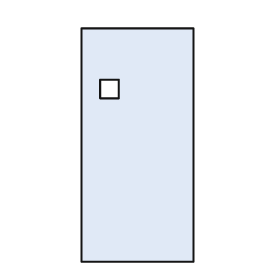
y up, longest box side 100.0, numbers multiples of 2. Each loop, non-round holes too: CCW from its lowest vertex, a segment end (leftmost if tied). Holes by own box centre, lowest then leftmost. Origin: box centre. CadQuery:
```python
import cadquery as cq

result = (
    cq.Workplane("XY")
    .moveTo(-24.0, -50.0)
    .lineTo(24.0, -50.0)
    .lineTo(24.0, 50.0)
    .lineTo(-24.0, 50.0)
    .close()
    .moveTo(-16.0, 20.0)
    .lineTo(-8.0, 20.0)
    .lineTo(-8.0, 28.0)
    .lineTo(-16.0, 28.0)
    .close()
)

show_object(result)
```